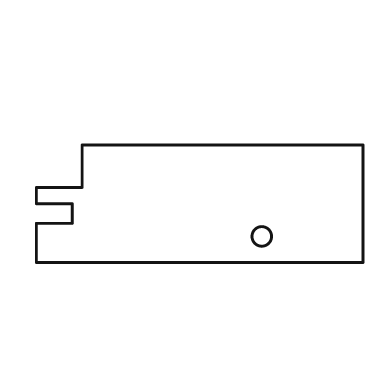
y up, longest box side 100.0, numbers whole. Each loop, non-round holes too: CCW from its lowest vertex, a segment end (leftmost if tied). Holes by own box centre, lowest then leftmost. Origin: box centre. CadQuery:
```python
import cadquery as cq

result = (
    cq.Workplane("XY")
    .moveTo(-50.0, -18.0)
    .lineTo(50.0, -18.0)
    .lineTo(50.0, 18.0)
    .lineTo(-36.0, 18.0)
    .lineTo(-36.0, 5.0)
    .lineTo(-50.0, 5.0)
    .lineTo(-50.0, 0.0)
    .lineTo(-39.0, 0.0)
    .lineTo(-39.0, -6.0)
    .lineTo(-50.0, -6.0)
    .close()
    .moveTo(19.0, -10.0)
    .circle(3.0)
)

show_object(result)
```